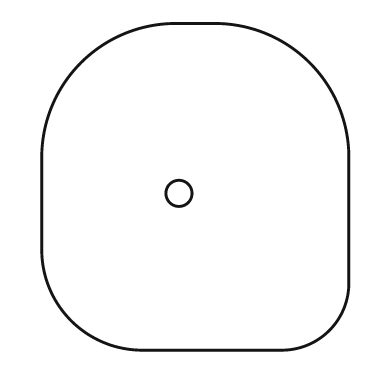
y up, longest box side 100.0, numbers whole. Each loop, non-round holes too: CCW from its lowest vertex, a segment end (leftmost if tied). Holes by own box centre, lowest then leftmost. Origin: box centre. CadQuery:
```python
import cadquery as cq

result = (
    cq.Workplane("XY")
    .moveTo(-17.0, -50.0)
    .lineTo(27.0, -50.0)
    .threePointArc((41.0, -44.0), (47.0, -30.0))
    .lineTo(47.0, 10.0)
    .threePointArc((35.0, 38.0), (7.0, 50.0))
    .lineTo(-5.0, 50.0)
    .threePointArc((-35.0, 38.0), (-47.0, 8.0))
    .lineTo(-47.0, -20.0)
    .threePointArc((-38.0, -41.0), (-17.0, -50.0))
    .close()
    .moveTo(-5.0, -2.0)
    .circle(4.0)
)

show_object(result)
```